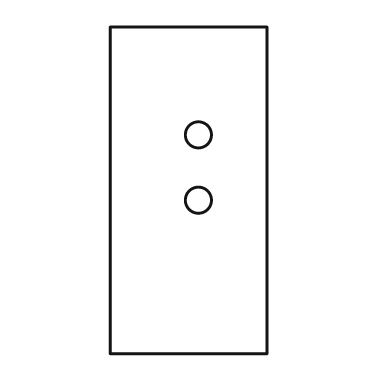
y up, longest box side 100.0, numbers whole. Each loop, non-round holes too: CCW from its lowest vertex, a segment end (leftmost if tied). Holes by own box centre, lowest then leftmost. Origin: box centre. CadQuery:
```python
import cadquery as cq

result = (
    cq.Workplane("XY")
    .moveTo(-24.0, -50.0)
    .lineTo(24.0, -50.0)
    .lineTo(24.0, 50.0)
    .lineTo(-24.0, 50.0)
    .close()
    .moveTo(3.0, -3.0)
    .circle(4.0)
    .moveTo(3.0, 17.0)
    .circle(4.0)
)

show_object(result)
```